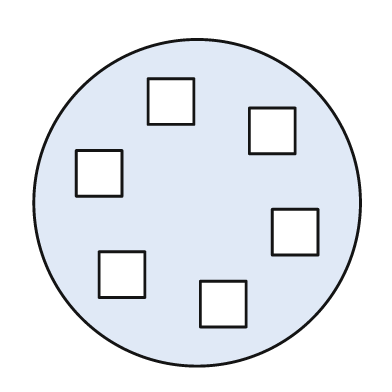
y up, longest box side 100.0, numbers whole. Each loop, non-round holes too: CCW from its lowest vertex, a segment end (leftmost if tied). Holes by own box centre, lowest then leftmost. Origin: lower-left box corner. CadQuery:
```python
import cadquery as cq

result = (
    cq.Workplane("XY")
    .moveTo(50.0, 50.0)
    .circle(50.0)
    .moveTo(51.0, 12.0)
    .lineTo(65.0, 12.0)
    .lineTo(65.0, 26.0)
    .lineTo(51.0, 26.0)
    .close()
    .moveTo(20.0, 21.0)
    .lineTo(34.0, 21.0)
    .lineTo(34.0, 35.0)
    .lineTo(20.0, 35.0)
    .close()
    .moveTo(73.0, 34.0)
    .lineTo(87.0, 34.0)
    .lineTo(87.0, 48.0)
    .lineTo(73.0, 48.0)
    .close()
    .moveTo(13.0, 52.0)
    .lineTo(27.0, 52.0)
    .lineTo(27.0, 66.0)
    .lineTo(13.0, 66.0)
    .close()
    .moveTo(66.0, 65.0)
    .lineTo(80.0, 65.0)
    .lineTo(80.0, 79.0)
    .lineTo(66.0, 79.0)
    .close()
    .moveTo(35.0, 74.0)
    .lineTo(49.0, 74.0)
    .lineTo(49.0, 88.0)
    .lineTo(35.0, 88.0)
    .close()
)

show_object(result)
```